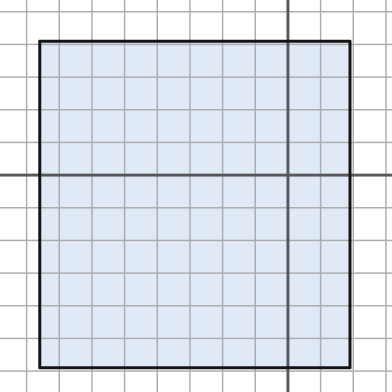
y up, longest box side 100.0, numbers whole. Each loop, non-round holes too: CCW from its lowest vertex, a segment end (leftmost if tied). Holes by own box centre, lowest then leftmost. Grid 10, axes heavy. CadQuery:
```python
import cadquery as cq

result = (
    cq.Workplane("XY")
    .moveTo(-76.0, -59.0)
    .lineTo(19.0, -59.0)
    .lineTo(19.0, 41.0)
    .lineTo(-76.0, 41.0)
    .close()
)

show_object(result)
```